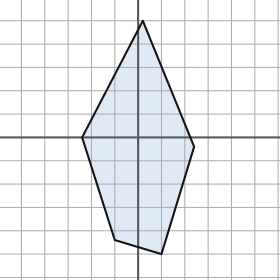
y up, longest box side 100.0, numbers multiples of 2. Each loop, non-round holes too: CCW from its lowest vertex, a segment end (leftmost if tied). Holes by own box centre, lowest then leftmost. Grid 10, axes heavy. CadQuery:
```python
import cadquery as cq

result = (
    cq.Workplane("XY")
    .moveTo(10.0, -50.0)
    .lineTo(24.0, -4.0)
    .lineTo(2.0, 50.0)
    .lineTo(-24.0, 0.0)
    .lineTo(-10.0, -44.0)
    .close()
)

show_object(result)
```